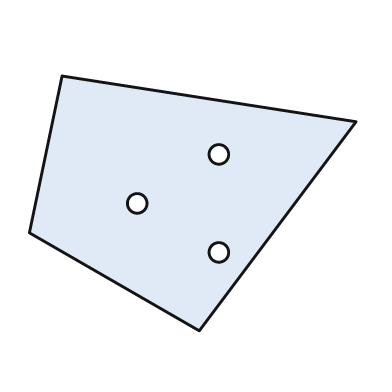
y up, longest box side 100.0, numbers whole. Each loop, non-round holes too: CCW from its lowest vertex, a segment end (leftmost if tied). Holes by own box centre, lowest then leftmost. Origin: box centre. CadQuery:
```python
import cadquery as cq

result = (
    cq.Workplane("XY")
    .moveTo(2.0, -39.0)
    .lineTo(50.0, 25.0)
    .lineTo(-40.0, 39.0)
    .lineTo(-50.0, -9.0)
    .close()
    .moveTo(8.0, -15.0)
    .circle(3.0)
    .moveTo(-17.0, 0.0)
    .circle(3.0)
    .moveTo(8.0, 15.0)
    .circle(3.0)
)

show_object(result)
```